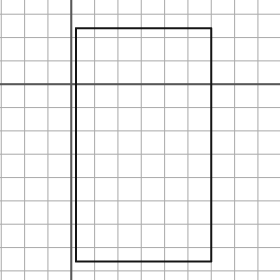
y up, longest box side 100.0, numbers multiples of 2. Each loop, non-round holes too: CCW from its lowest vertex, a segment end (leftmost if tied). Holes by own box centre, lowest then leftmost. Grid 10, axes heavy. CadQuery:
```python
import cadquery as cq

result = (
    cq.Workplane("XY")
    .moveTo(2.0, -76.0)
    .lineTo(60.0, -76.0)
    .lineTo(60.0, 24.0)
    .lineTo(2.0, 24.0)
    .close()
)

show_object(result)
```